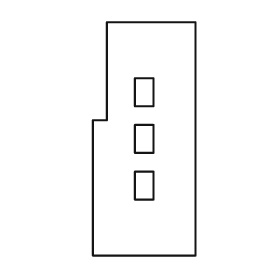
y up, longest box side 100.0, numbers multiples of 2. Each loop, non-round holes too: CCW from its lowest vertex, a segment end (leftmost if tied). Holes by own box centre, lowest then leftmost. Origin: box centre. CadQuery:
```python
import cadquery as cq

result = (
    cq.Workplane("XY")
    .moveTo(-22.0, -50.0)
    .lineTo(22.0, -50.0)
    .lineTo(22.0, 50.0)
    .lineTo(-16.0, 50.0)
    .lineTo(-16.0, 8.0)
    .lineTo(-22.0, 8.0)
    .close()
    .moveTo(-4.0, -26.0)
    .lineTo(4.0, -26.0)
    .lineTo(4.0, -14.0)
    .lineTo(-4.0, -14.0)
    .close()
    .moveTo(-4.0, -6.0)
    .lineTo(4.0, -6.0)
    .lineTo(4.0, 6.0)
    .lineTo(-4.0, 6.0)
    .close()
    .moveTo(-4.0, 14.0)
    .lineTo(4.0, 14.0)
    .lineTo(4.0, 26.0)
    .lineTo(-4.0, 26.0)
    .close()
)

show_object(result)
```